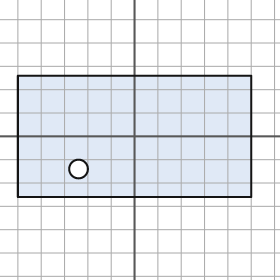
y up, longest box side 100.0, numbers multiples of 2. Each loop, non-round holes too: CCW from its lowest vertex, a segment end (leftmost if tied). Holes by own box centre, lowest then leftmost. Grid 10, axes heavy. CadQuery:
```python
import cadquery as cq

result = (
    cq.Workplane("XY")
    .moveTo(-50.0, -26.0)
    .lineTo(50.0, -26.0)
    .lineTo(50.0, 26.0)
    .lineTo(-50.0, 26.0)
    .close()
    .moveTo(-24.0, -14.0)
    .circle(4.0)
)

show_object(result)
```